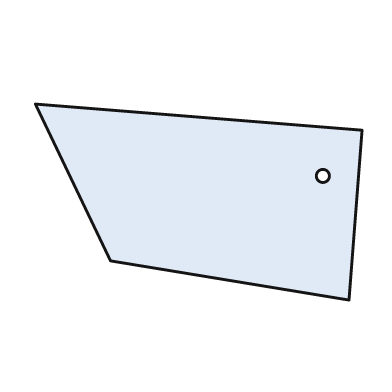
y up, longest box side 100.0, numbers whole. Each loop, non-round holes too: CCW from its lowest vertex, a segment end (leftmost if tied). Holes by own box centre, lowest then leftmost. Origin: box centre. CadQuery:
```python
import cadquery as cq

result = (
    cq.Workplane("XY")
    .moveTo(46.0, -30.0)
    .lineTo(50.0, 22.0)
    .lineTo(-50.0, 30.0)
    .lineTo(-27.0, -18.0)
    .close()
    .moveTo(38.0, 8.0)
    .circle(2.0)
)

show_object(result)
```